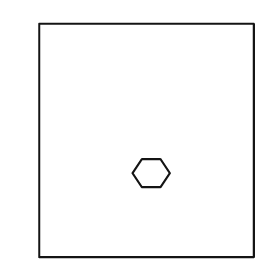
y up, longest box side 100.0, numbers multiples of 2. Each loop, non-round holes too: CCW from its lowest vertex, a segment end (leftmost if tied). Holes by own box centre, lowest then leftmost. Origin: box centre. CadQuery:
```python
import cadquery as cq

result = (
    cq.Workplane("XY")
    .moveTo(-46.0, -50.0)
    .lineTo(46.0, -50.0)
    .lineTo(46.0, 50.0)
    .lineTo(-46.0, 50.0)
    .close()
    .moveTo(-2.0, -20.0)
    .lineTo(6.0, -20.0)
    .lineTo(10.0, -14.0)
    .lineTo(6.0, -8.0)
    .lineTo(-2.0, -8.0)
    .lineTo(-6.0, -14.0)
    .close()
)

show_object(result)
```